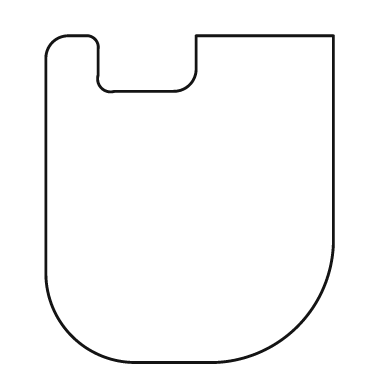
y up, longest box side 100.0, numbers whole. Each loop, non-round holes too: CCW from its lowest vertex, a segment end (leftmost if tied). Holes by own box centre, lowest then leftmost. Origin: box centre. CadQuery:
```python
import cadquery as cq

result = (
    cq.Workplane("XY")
    .moveTo(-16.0, -50.0)
    .lineTo(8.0, -50.0)
    .threePointArc((33.0, -39.0), (44.0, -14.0))
    .lineTo(44.0, 50.0)
    .lineTo(2.0, 50.0)
    .lineTo(2.0, 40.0)
    .threePointArc((0.0, 35.0), (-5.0, 33.0))
    .lineTo(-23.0, 33.0)
    .threePointArc((-27.0, 34.0), (-28.0, 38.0))
    .lineTo(-28.0, 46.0)
    .threePointArc((-29.0, 49.0), (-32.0, 50.0))
    .lineTo(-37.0, 50.0)
    .threePointArc((-42.0, 48.0), (-44.0, 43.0))
    .lineTo(-44.0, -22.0)
    .threePointArc((-36.0, -42.0), (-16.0, -50.0))
    .close()
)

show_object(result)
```